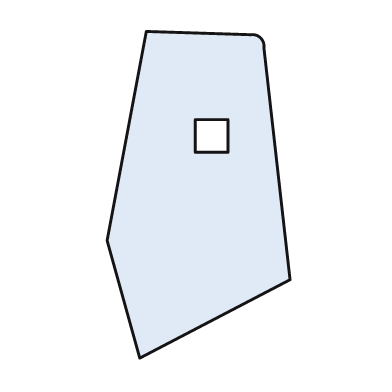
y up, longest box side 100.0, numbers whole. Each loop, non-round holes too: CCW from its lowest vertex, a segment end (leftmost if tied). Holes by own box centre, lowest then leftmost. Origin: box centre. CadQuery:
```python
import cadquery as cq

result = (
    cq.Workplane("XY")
    .moveTo(-18.0, -50.0)
    .lineTo(28.0, -26.0)
    .lineTo(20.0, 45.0)
    .threePointArc((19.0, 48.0), (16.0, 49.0))
    .lineTo(-16.0, 50.0)
    .lineTo(-28.0, -14.0)
    .close()
    .moveTo(-1.0, 13.0)
    .lineTo(9.0, 13.0)
    .lineTo(9.0, 23.0)
    .lineTo(-1.0, 23.0)
    .close()
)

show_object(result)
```